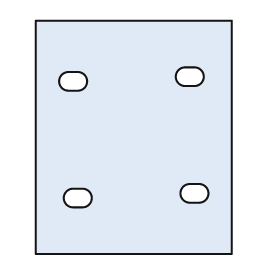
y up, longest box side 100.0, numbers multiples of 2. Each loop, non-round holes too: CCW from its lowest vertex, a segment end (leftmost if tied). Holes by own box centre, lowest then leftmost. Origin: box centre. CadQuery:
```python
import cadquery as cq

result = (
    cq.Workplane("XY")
    .moveTo(-42.0, -50.0)
    .lineTo(42.0, -50.0)
    .lineTo(42.0, 50.0)
    .lineTo(-42.0, 50.0)
    .close()
    .moveTo(-26.0, -30.0)
    .lineTo(-22.0, -30.0)
    .threePointArc((-18.0, -26.0), (-22.0, -22.0))
    .lineTo(-26.0, -22.0)
    .threePointArc((-30.0, -26.0), (-26.0, -30.0))
    .close()
    .moveTo(24.0, -28.0)
    .lineTo(28.0, -28.0)
    .threePointArc((32.0, -24.0), (28.0, -20.0))
    .lineTo(24.0, -20.0)
    .threePointArc((20.0, -24.0), (24.0, -28.0))
    .close()
    .moveTo(-28.0, 20.0)
    .lineTo(-24.0, 20.0)
    .threePointArc((-20.0, 24.0), (-24.0, 28.0))
    .lineTo(-28.0, 28.0)
    .threePointArc((-32.0, 24.0), (-28.0, 20.0))
    .close()
    .moveTo(22.0, 22.0)
    .lineTo(26.0, 22.0)
    .threePointArc((30.0, 26.0), (26.0, 30.0))
    .lineTo(22.0, 30.0)
    .threePointArc((18.0, 26.0), (22.0, 22.0))
    .close()
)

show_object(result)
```